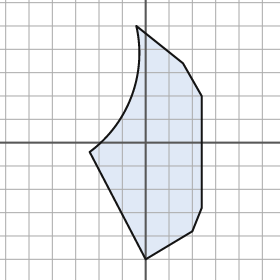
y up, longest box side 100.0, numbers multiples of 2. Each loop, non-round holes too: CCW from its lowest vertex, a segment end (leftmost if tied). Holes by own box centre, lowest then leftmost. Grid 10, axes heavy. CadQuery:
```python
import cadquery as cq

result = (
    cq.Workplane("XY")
    .moveTo(0.0, -50.0)
    .lineTo(20.0, -38.0)
    .lineTo(24.0, -28.0)
    .lineTo(24.0, 20.0)
    .lineTo(16.0, 34.0)
    .lineTo(-4.0, 50.0)
    .threePointArc((-6.0, 20.0), (-24.0, -4.0))
    .close()
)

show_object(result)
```